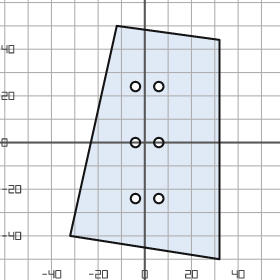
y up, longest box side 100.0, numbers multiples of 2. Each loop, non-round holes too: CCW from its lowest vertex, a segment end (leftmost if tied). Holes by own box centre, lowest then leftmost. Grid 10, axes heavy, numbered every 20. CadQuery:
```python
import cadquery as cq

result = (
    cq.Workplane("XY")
    .moveTo(32.0, -50.0)
    .lineTo(32.0, 44.0)
    .lineTo(-12.0, 50.0)
    .lineTo(-32.0, -40.0)
    .close()
    .moveTo(-4.0, -24.0)
    .circle(2.0)
    .moveTo(6.0, -24.0)
    .circle(2.0)
    .moveTo(-4.0, 0.0)
    .circle(2.0)
    .moveTo(6.0, 0.0)
    .circle(2.0)
    .moveTo(-4.0, 24.0)
    .circle(2.0)
    .moveTo(6.0, 24.0)
    .circle(2.0)
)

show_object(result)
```